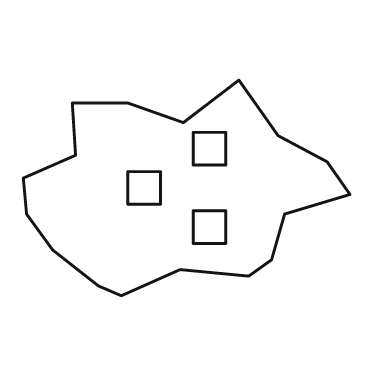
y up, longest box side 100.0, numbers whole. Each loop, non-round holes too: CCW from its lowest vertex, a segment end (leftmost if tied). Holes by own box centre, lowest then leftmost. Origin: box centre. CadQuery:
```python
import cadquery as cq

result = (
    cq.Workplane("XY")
    .moveTo(-20.0, -33.0)
    .lineTo(-2.0, -25.0)
    .lineTo(19.0, -27.0)
    .lineTo(26.0, -22.0)
    .lineTo(30.0, -8.0)
    .lineTo(50.0, -2.0)
    .lineTo(43.0, 8.0)
    .lineTo(28.0, 16.0)
    .lineTo(16.0, 33.0)
    .lineTo(-1.0, 20.0)
    .lineTo(-18.0, 26.0)
    .lineTo(-35.0, 26.0)
    .lineTo(-34.0, 10.0)
    .lineTo(-50.0, 3.0)
    .lineTo(-49.0, -8.0)
    .lineTo(-41.0, -19.0)
    .lineTo(-27.0, -30.0)
    .close()
    .moveTo(2.0, -17.0)
    .lineTo(12.0, -17.0)
    .lineTo(12.0, -7.0)
    .lineTo(2.0, -7.0)
    .close()
    .moveTo(-18.0, -5.0)
    .lineTo(-8.0, -5.0)
    .lineTo(-8.0, 5.0)
    .lineTo(-18.0, 5.0)
    .close()
    .moveTo(2.0, 7.0)
    .lineTo(12.0, 7.0)
    .lineTo(12.0, 17.0)
    .lineTo(2.0, 17.0)
    .close()
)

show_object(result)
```